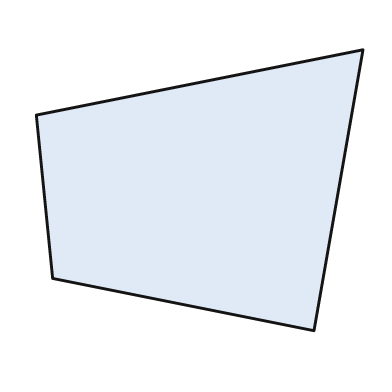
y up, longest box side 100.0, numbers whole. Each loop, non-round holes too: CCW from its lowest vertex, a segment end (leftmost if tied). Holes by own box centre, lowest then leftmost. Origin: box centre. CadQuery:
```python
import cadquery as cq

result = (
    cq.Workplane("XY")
    .moveTo(35.0, -43.0)
    .lineTo(50.0, 43.0)
    .lineTo(-50.0, 23.0)
    .lineTo(-45.0, -27.0)
    .close()
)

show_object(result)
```